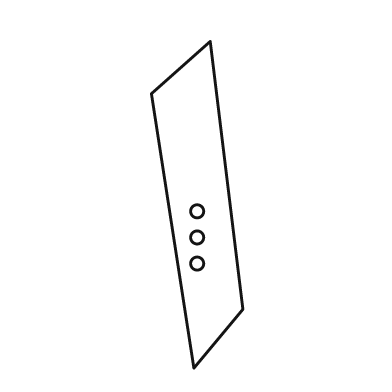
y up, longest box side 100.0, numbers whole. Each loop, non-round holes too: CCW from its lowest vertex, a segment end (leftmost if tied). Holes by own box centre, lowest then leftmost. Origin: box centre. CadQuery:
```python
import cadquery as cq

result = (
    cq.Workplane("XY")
    .moveTo(-1.0, -50.0)
    .lineTo(14.0, -32.0)
    .lineTo(4.0, 50.0)
    .lineTo(-14.0, 34.0)
    .close()
    .moveTo(0.0, -18.0)
    .circle(2.0)
    .moveTo(0.0, -10.0)
    .circle(2.0)
    .moveTo(0.0, -2.0)
    .circle(2.0)
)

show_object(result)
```